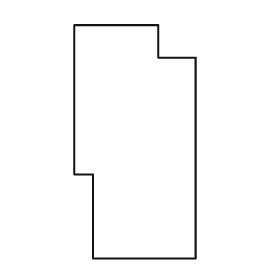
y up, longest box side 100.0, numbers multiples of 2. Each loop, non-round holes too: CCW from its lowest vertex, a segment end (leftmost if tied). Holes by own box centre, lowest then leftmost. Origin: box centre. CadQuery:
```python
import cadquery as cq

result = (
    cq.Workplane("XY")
    .moveTo(-18.0, -50.0)
    .lineTo(26.0, -50.0)
    .lineTo(26.0, 36.0)
    .lineTo(10.0, 36.0)
    .lineTo(10.0, 50.0)
    .lineTo(-26.0, 50.0)
    .lineTo(-26.0, -14.0)
    .lineTo(-18.0, -14.0)
    .close()
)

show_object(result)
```